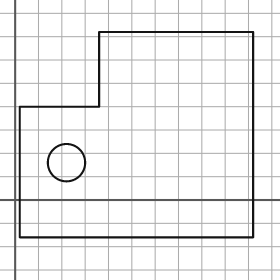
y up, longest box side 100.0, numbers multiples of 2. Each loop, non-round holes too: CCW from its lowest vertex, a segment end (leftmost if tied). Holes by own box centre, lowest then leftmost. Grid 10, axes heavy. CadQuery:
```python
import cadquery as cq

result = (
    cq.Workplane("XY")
    .moveTo(2.0, -16.0)
    .lineTo(102.0, -16.0)
    .lineTo(102.0, 72.0)
    .lineTo(36.0, 72.0)
    .lineTo(36.0, 40.0)
    .lineTo(2.0, 40.0)
    .close()
    .moveTo(22.0, 16.0)
    .circle(8.0)
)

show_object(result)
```